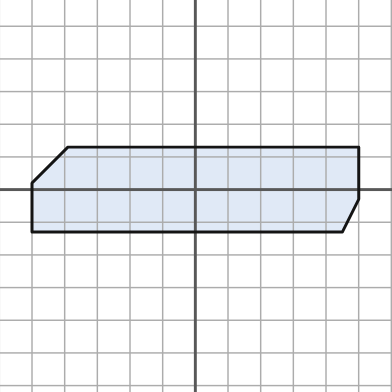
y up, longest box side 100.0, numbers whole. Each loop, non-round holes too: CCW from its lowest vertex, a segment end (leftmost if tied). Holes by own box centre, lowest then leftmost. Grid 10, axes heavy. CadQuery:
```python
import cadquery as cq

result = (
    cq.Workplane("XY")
    .moveTo(-50.0, -13.0)
    .lineTo(45.0, -13.0)
    .lineTo(50.0, -3.0)
    .lineTo(50.0, 13.0)
    .lineTo(-39.0, 13.0)
    .lineTo(-50.0, 2.0)
    .close()
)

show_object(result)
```